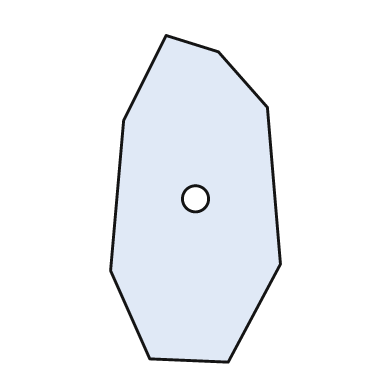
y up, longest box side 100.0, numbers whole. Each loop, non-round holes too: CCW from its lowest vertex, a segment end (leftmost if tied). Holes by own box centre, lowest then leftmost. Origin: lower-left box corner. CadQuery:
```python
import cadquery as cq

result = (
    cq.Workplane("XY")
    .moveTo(36.0, 0.0)
    .lineTo(52.0, 30.0)
    .lineTo(48.0, 78.0)
    .lineTo(33.0, 95.0)
    .lineTo(17.0, 100.0)
    .lineTo(4.0, 74.0)
    .lineTo(0.0, 28.0)
    .lineTo(12.0, 1.0)
    .close()
    .moveTo(26.0, 50.0)
    .circle(4.0)
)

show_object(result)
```